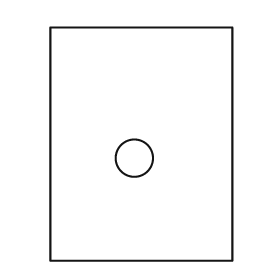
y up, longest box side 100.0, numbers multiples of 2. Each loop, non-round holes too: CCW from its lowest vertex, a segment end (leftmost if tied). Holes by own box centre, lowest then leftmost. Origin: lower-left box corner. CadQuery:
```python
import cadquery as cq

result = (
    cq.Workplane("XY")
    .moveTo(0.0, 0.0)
    .lineTo(78.0, 0.0)
    .lineTo(78.0, 100.0)
    .lineTo(0.0, 100.0)
    .close()
    .moveTo(36.0, 44.0)
    .circle(8.0)
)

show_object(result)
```